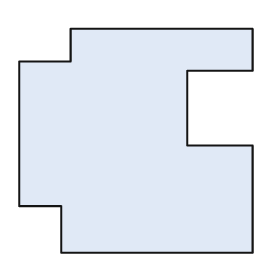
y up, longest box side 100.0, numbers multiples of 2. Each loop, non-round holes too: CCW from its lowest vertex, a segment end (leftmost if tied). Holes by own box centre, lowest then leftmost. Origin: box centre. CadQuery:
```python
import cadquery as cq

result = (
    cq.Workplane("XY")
    .moveTo(-32.0, -48.0)
    .lineTo(50.0, -48.0)
    .lineTo(50.0, -2.0)
    .lineTo(22.0, -2.0)
    .lineTo(22.0, 30.0)
    .lineTo(50.0, 30.0)
    .lineTo(50.0, 48.0)
    .lineTo(-28.0, 48.0)
    .lineTo(-28.0, 34.0)
    .lineTo(-50.0, 34.0)
    .lineTo(-50.0, -28.0)
    .lineTo(-32.0, -28.0)
    .close()
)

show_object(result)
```